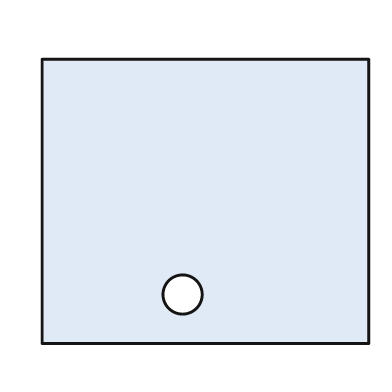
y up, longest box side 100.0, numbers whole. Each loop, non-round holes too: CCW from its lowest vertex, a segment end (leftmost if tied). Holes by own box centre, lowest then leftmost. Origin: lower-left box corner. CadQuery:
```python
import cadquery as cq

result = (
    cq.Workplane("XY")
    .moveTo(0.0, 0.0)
    .lineTo(100.0, 0.0)
    .lineTo(100.0, 87.0)
    .lineTo(0.0, 87.0)
    .close()
    .moveTo(43.0, 15.0)
    .circle(6.0)
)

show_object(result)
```